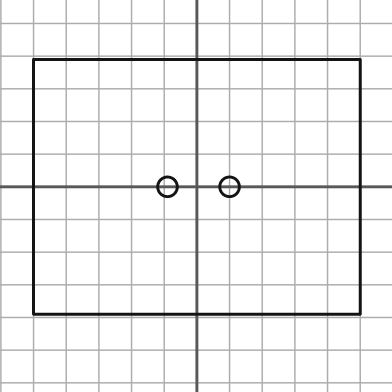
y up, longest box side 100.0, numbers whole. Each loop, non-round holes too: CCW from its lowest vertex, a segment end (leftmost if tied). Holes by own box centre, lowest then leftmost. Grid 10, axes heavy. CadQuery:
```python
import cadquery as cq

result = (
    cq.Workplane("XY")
    .moveTo(-50.0, -39.0)
    .lineTo(50.0, -39.0)
    .lineTo(50.0, 39.0)
    .lineTo(-50.0, 39.0)
    .close()
    .moveTo(-9.0, 0.0)
    .circle(3.0)
    .moveTo(10.0, 0.0)
    .circle(3.0)
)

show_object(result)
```